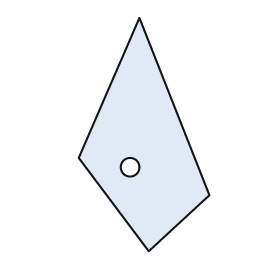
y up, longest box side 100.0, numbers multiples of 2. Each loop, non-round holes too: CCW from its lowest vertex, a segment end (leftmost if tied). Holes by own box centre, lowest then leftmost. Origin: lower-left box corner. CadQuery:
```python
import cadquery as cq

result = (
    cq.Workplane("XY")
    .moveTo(30.0, 0.0)
    .lineTo(56.0, 24.0)
    .lineTo(26.0, 100.0)
    .lineTo(0.0, 40.0)
    .close()
    .moveTo(22.0, 36.0)
    .circle(4.0)
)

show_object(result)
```